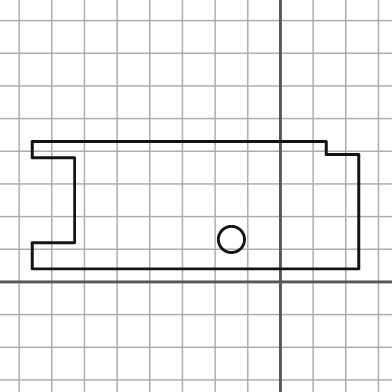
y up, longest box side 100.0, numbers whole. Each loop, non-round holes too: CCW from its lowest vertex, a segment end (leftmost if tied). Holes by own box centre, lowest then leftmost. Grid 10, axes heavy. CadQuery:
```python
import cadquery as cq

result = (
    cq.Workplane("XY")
    .moveTo(-76.0, 4.0)
    .lineTo(24.0, 4.0)
    .lineTo(24.0, 39.0)
    .lineTo(14.0, 39.0)
    .lineTo(14.0, 43.0)
    .lineTo(-76.0, 43.0)
    .lineTo(-76.0, 38.0)
    .lineTo(-63.0, 38.0)
    .lineTo(-63.0, 12.0)
    .lineTo(-76.0, 12.0)
    .close()
    .moveTo(-15.0, 13.0)
    .circle(4.0)
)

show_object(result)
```